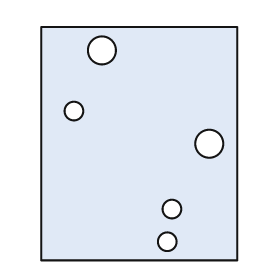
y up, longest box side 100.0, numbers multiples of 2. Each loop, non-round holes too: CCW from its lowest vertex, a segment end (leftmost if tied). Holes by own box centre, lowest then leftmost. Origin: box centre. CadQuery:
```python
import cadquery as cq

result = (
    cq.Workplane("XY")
    .moveTo(-42.0, -50.0)
    .lineTo(42.0, -50.0)
    .lineTo(42.0, 50.0)
    .lineTo(-42.0, 50.0)
    .close()
    .moveTo(12.0, -42.0)
    .circle(4.0)
    .moveTo(14.0, -28.0)
    .circle(4.0)
    .moveTo(30.0, 0.0)
    .circle(6.0)
    .moveTo(-28.0, 14.0)
    .circle(4.0)
    .moveTo(-16.0, 40.0)
    .circle(6.0)
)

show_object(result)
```